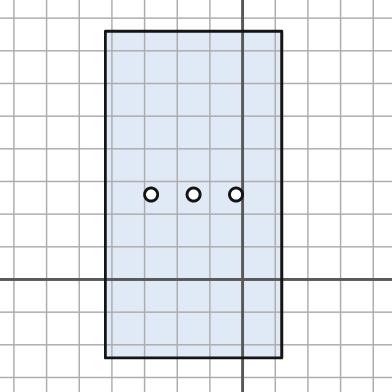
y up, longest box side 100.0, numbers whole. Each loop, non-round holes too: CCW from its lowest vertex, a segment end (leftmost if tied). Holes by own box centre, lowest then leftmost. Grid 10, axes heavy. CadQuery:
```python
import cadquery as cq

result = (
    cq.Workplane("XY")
    .moveTo(-42.0, -24.0)
    .lineTo(12.0, -24.0)
    .lineTo(12.0, 76.0)
    .lineTo(-42.0, 76.0)
    .close()
    .moveTo(-28.0, 26.0)
    .circle(2.0)
    .moveTo(-15.0, 26.0)
    .circle(2.0)
    .moveTo(-2.0, 26.0)
    .circle(2.0)
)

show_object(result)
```